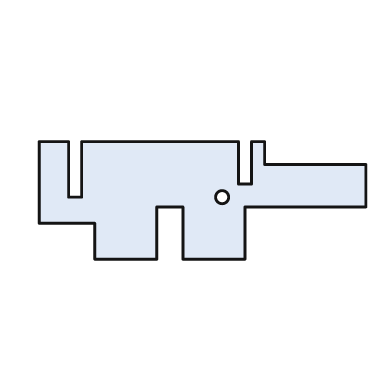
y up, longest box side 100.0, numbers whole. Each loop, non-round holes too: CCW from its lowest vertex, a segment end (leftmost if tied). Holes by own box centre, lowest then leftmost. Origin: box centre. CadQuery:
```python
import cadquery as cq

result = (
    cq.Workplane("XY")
    .moveTo(-33.0, -18.0)
    .lineTo(-14.0, -18.0)
    .lineTo(-14.0, -2.0)
    .lineTo(-6.0, -2.0)
    .lineTo(-6.0, -18.0)
    .lineTo(13.0, -18.0)
    .lineTo(13.0, -2.0)
    .lineTo(50.0, -2.0)
    .lineTo(50.0, 11.0)
    .lineTo(19.0, 11.0)
    .lineTo(19.0, 18.0)
    .lineTo(15.0, 18.0)
    .lineTo(15.0, 5.0)
    .lineTo(11.0, 5.0)
    .lineTo(11.0, 18.0)
    .lineTo(-37.0, 18.0)
    .lineTo(-37.0, 1.0)
    .lineTo(-41.0, 1.0)
    .lineTo(-41.0, 18.0)
    .lineTo(-50.0, 18.0)
    .lineTo(-50.0, -7.0)
    .lineTo(-33.0, -7.0)
    .close()
    .moveTo(6.0, 1.0)
    .circle(2.0)
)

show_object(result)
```